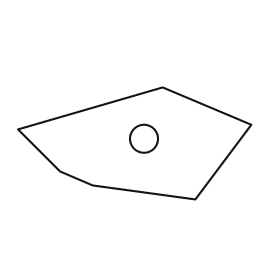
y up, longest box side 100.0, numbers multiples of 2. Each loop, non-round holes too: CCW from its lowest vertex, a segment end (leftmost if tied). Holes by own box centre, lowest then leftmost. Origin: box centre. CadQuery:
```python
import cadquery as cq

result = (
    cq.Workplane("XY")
    .moveTo(26.0, -24.0)
    .lineTo(50.0, 8.0)
    .lineTo(12.0, 24.0)
    .lineTo(-50.0, 6.0)
    .lineTo(-32.0, -12.0)
    .lineTo(-18.0, -18.0)
    .close()
    .moveTo(4.0, 2.0)
    .circle(6.0)
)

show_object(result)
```